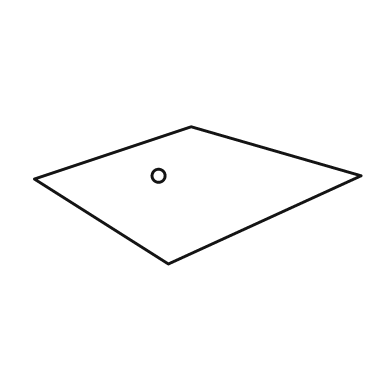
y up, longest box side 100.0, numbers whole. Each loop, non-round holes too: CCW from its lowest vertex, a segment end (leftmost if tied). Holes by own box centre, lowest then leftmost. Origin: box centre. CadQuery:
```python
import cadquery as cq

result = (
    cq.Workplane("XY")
    .moveTo(-9.0, -21.0)
    .lineTo(50.0, 6.0)
    .lineTo(-2.0, 21.0)
    .lineTo(-50.0, 5.0)
    .close()
    .moveTo(-12.0, 6.0)
    .circle(2.0)
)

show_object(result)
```